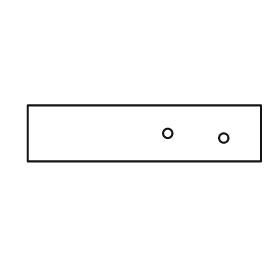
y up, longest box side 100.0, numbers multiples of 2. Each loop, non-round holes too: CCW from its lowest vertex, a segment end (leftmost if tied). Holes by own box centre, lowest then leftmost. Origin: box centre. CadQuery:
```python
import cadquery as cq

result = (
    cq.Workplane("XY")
    .moveTo(-50.0, -12.0)
    .lineTo(50.0, -12.0)
    .lineTo(50.0, 12.0)
    .lineTo(-50.0, 12.0)
    .close()
    .moveTo(34.0, -2.0)
    .circle(2.0)
    .moveTo(10.0, 0.0)
    .circle(2.0)
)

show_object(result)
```